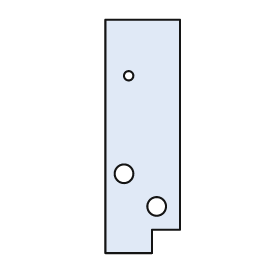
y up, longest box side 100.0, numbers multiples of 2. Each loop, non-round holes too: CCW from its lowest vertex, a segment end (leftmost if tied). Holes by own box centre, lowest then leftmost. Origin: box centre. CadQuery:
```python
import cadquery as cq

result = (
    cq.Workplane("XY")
    .moveTo(-16.0, -50.0)
    .lineTo(4.0, -50.0)
    .lineTo(4.0, -40.0)
    .lineTo(16.0, -40.0)
    .lineTo(16.0, 50.0)
    .lineTo(-16.0, 50.0)
    .close()
    .moveTo(6.0, -30.0)
    .circle(4.0)
    .moveTo(-8.0, -16.0)
    .circle(4.0)
    .moveTo(-6.0, 26.0)
    .circle(2.0)
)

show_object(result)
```